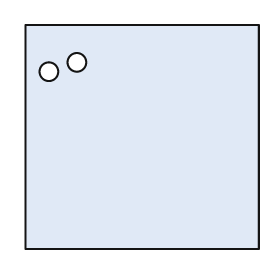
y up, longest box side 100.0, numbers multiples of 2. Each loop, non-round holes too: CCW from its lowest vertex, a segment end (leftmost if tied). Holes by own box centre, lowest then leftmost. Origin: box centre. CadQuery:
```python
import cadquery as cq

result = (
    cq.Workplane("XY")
    .moveTo(-50.0, -48.0)
    .lineTo(50.0, -48.0)
    .lineTo(50.0, 48.0)
    .lineTo(-50.0, 48.0)
    .close()
    .moveTo(-40.0, 28.0)
    .circle(4.0)
    .moveTo(-28.0, 32.0)
    .circle(4.0)
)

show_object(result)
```